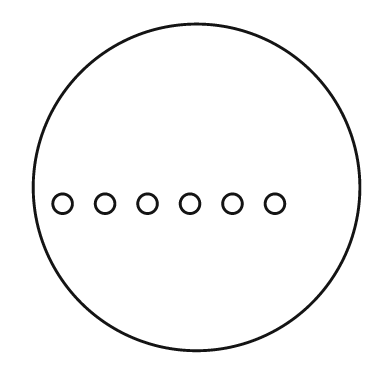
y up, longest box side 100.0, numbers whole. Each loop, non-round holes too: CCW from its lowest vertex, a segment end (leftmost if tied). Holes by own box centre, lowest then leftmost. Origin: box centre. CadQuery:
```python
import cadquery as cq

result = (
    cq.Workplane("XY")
    .moveTo(0.0, 0.0)
    .circle(50.0)
    .moveTo(-41.0, -5.0)
    .circle(3.0)
    .moveTo(-28.0, -5.0)
    .circle(3.0)
    .moveTo(-15.0, -5.0)
    .circle(3.0)
    .moveTo(-2.0, -5.0)
    .circle(3.0)
    .moveTo(11.0, -5.0)
    .circle(3.0)
    .moveTo(24.0, -5.0)
    .circle(3.0)
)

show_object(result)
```